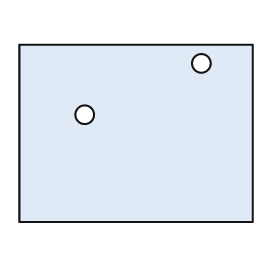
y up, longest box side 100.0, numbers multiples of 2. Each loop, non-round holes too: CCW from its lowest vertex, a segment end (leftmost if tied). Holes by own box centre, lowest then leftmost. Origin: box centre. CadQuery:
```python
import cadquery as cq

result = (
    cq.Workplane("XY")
    .moveTo(-50.0, -38.0)
    .lineTo(50.0, -38.0)
    .lineTo(50.0, 38.0)
    .lineTo(-50.0, 38.0)
    .close()
    .moveTo(-22.0, 8.0)
    .circle(4.0)
    .moveTo(28.0, 30.0)
    .circle(4.0)
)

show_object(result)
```